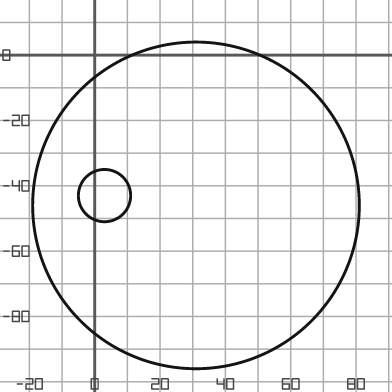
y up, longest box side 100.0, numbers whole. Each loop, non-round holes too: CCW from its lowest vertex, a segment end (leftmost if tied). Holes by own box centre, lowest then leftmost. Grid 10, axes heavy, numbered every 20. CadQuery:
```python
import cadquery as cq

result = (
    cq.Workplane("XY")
    .moveTo(31.0, -46.0)
    .circle(50.0)
    .moveTo(3.0, -43.0)
    .circle(8.0)
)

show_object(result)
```